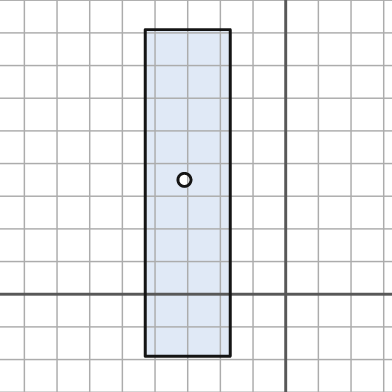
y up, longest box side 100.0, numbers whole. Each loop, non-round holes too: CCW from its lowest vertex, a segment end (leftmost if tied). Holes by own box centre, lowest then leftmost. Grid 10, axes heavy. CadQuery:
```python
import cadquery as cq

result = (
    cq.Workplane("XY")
    .moveTo(-43.0, -19.0)
    .lineTo(-17.0, -19.0)
    .lineTo(-17.0, 81.0)
    .lineTo(-43.0, 81.0)
    .close()
    .moveTo(-31.0, 35.0)
    .circle(2.0)
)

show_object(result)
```